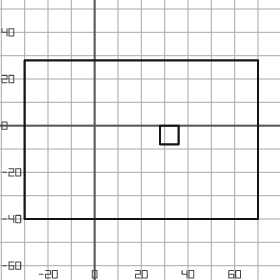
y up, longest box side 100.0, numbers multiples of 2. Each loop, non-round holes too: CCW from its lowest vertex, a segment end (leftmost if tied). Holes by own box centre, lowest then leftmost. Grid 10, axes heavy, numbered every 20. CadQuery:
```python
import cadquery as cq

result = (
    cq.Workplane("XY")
    .moveTo(-30.0, -40.0)
    .lineTo(70.0, -40.0)
    .lineTo(70.0, 28.0)
    .lineTo(-30.0, 28.0)
    .close()
    .moveTo(28.0, -8.0)
    .lineTo(36.0, -8.0)
    .lineTo(36.0, 0.0)
    .lineTo(28.0, 0.0)
    .close()
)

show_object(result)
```